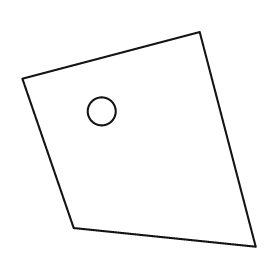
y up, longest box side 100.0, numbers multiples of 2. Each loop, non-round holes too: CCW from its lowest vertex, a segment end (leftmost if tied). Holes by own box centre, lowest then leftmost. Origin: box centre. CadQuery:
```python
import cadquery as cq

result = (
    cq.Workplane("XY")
    .moveTo(50.0, -46.0)
    .lineTo(26.0, 46.0)
    .lineTo(-50.0, 26.0)
    .lineTo(-28.0, -38.0)
    .close()
    .moveTo(-16.0, 12.0)
    .circle(6.0)
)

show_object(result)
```